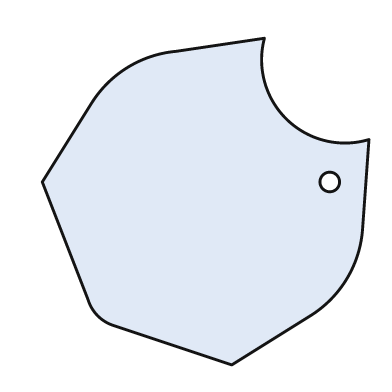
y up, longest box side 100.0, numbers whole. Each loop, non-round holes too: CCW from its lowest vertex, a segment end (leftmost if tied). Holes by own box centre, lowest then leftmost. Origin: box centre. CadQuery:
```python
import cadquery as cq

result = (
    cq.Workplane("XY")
    .moveTo(8.0, -50.0)
    .lineTo(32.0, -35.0)
    .threePointArc((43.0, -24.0), (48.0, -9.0))
    .lineTo(50.0, 19.0)
    .threePointArc((25.0, 25.0), (18.0, 50.0))
    .lineTo(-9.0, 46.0)
    .threePointArc((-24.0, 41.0), (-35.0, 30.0))
    .lineTo(-50.0, 6.0)
    .lineTo(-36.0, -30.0)
    .threePointArc((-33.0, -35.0), (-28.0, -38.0))
    .close()
    .moveTo(38.0, 6.0)
    .circle(3.0)
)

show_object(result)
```